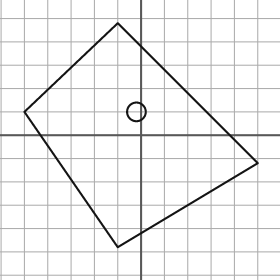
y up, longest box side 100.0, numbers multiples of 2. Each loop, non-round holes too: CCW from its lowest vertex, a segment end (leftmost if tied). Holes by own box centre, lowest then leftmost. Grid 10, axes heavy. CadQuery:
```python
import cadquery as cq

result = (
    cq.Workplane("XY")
    .moveTo(-10.0, -48.0)
    .lineTo(50.0, -12.0)
    .lineTo(-10.0, 48.0)
    .lineTo(-50.0, 10.0)
    .close()
    .moveTo(-2.0, 10.0)
    .circle(4.0)
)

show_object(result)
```